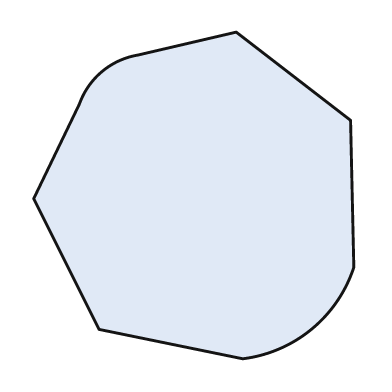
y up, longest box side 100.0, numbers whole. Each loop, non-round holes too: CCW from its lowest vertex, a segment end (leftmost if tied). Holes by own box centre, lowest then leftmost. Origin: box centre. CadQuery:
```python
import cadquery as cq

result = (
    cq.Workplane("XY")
    .moveTo(15.0, -50.0)
    .threePointArc((36.0, -41.0), (49.0, -22.0))
    .lineTo(48.0, 23.0)
    .lineTo(13.0, 50.0)
    .lineTo(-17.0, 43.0)
    .threePointArc((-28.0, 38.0), (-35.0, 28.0))
    .lineTo(-49.0, -1.0)
    .lineTo(-29.0, -41.0)
    .close()
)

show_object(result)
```